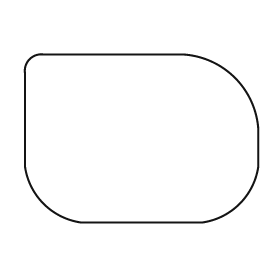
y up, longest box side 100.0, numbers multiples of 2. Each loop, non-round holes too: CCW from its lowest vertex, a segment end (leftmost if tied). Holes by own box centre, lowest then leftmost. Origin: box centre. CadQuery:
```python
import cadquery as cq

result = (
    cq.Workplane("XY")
    .moveTo(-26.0, -36.0)
    .lineTo(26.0, -36.0)
    .threePointArc((42.0, -28.0), (50.0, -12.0))
    .lineTo(50.0, 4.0)
    .threePointArc((40.0, 26.0), (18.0, 36.0))
    .lineTo(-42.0, 36.0)
    .threePointArc((-48.0, 34.0), (-50.0, 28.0))
    .lineTo(-50.0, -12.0)
    .threePointArc((-42.0, -28.0), (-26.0, -36.0))
    .close()
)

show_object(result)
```